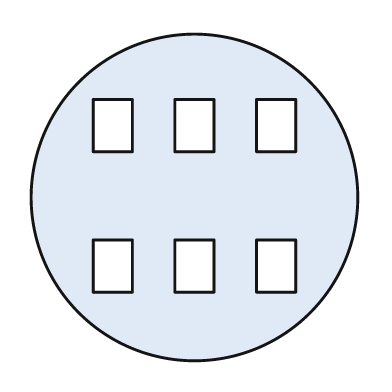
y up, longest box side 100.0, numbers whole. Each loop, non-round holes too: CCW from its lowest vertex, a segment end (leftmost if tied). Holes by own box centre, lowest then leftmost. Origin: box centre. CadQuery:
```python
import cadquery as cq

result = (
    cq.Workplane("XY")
    .moveTo(0.0, 0.0)
    .circle(50.0)
    .moveTo(-31.0, -29.0)
    .lineTo(-19.0, -29.0)
    .lineTo(-19.0, -13.0)
    .lineTo(-31.0, -13.0)
    .close()
    .moveTo(-6.0, -29.0)
    .lineTo(6.0, -29.0)
    .lineTo(6.0, -13.0)
    .lineTo(-6.0, -13.0)
    .close()
    .moveTo(19.0, -29.0)
    .lineTo(31.0, -29.0)
    .lineTo(31.0, -13.0)
    .lineTo(19.0, -13.0)
    .close()
    .moveTo(-31.0, 14.0)
    .lineTo(-19.0, 14.0)
    .lineTo(-19.0, 30.0)
    .lineTo(-31.0, 30.0)
    .close()
    .moveTo(-6.0, 14.0)
    .lineTo(6.0, 14.0)
    .lineTo(6.0, 30.0)
    .lineTo(-6.0, 30.0)
    .close()
    .moveTo(19.0, 14.0)
    .lineTo(31.0, 14.0)
    .lineTo(31.0, 30.0)
    .lineTo(19.0, 30.0)
    .close()
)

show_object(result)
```